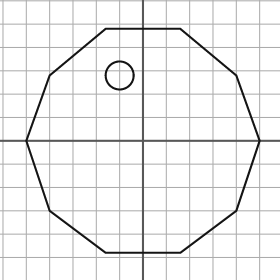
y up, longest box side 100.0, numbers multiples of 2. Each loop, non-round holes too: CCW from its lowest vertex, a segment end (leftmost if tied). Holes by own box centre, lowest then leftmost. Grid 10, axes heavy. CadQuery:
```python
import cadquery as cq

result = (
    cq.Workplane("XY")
    .moveTo(-16.0, -48.0)
    .lineTo(16.0, -48.0)
    .lineTo(40.0, -30.0)
    .lineTo(50.0, 0.0)
    .lineTo(40.0, 28.0)
    .lineTo(16.0, 48.0)
    .lineTo(-16.0, 48.0)
    .lineTo(-40.0, 28.0)
    .lineTo(-50.0, 0.0)
    .lineTo(-40.0, -30.0)
    .close()
    .moveTo(-10.0, 28.0)
    .circle(6.0)
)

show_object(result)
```